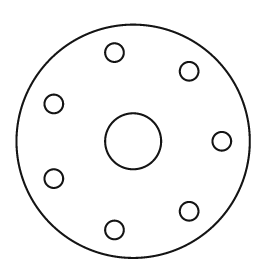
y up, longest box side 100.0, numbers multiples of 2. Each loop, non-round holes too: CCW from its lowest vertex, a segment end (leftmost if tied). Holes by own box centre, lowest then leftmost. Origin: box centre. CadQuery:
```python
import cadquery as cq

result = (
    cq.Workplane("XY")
    .moveTo(0.0, 0.0)
    .circle(50.0)
    .moveTo(-8.0, -38.0)
    .circle(4.0)
    .moveTo(24.0, -30.0)
    .circle(4.0)
    .moveTo(-34.0, -16.0)
    .circle(4.0)
    .moveTo(0.0, 0.0)
    .circle(12.0)
    .moveTo(38.0, 0.0)
    .circle(4.0)
    .moveTo(-34.0, 16.0)
    .circle(4.0)
    .moveTo(24.0, 30.0)
    .circle(4.0)
    .moveTo(-8.0, 38.0)
    .circle(4.0)
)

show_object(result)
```